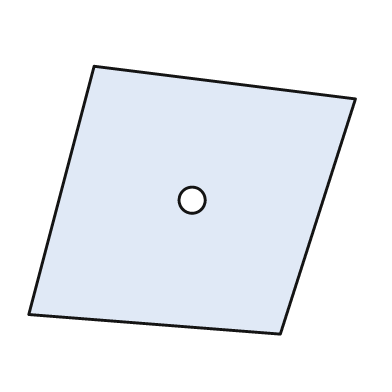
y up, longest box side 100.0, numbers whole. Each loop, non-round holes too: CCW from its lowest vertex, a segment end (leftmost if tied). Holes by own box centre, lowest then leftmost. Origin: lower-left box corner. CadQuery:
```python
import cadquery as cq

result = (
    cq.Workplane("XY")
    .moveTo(77.0, 0.0)
    .lineTo(100.0, 72.0)
    .lineTo(20.0, 82.0)
    .lineTo(0.0, 6.0)
    .close()
    .moveTo(50.0, 41.0)
    .circle(4.0)
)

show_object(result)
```